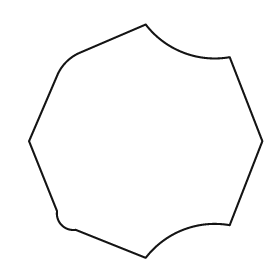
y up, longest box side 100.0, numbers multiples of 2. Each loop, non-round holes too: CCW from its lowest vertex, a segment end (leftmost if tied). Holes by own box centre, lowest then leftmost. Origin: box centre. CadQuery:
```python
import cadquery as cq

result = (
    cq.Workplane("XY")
    .moveTo(0.0, -50.0)
    .threePointArc((16.0, -38.0), (36.0, -36.0))
    .lineTo(50.0, 0.0)
    .lineTo(36.0, 36.0)
    .threePointArc((16.0, 38.0), (0.0, 50.0))
    .lineTo(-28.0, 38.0)
    .threePointArc((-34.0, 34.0), (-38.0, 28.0))
    .lineTo(-50.0, 0.0)
    .lineTo(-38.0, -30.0)
    .threePointArc((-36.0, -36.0), (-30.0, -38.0))
    .close()
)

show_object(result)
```